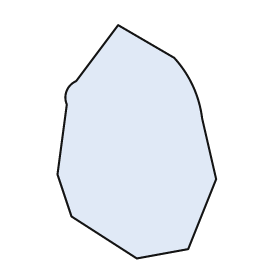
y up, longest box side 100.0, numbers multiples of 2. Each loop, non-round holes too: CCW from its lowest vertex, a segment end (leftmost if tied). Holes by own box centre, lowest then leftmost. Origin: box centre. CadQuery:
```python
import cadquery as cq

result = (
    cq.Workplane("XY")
    .moveTo(0.0, -50.0)
    .lineTo(22.0, -46.0)
    .lineTo(34.0, -16.0)
    .lineTo(28.0, 10.0)
    .threePointArc((24.0, 24.0), (16.0, 36.0))
    .lineTo(-8.0, 50.0)
    .lineTo(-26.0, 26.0)
    .threePointArc((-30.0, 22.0), (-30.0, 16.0))
    .lineTo(-34.0, -14.0)
    .lineTo(-28.0, -32.0)
    .close()
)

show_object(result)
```